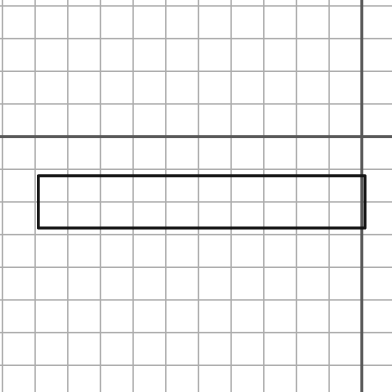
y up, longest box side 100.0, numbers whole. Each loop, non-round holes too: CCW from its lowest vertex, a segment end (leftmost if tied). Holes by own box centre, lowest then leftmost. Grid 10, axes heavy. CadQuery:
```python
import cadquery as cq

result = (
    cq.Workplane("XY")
    .moveTo(-99.0, -28.0)
    .lineTo(1.0, -28.0)
    .lineTo(1.0, -12.0)
    .lineTo(-99.0, -12.0)
    .close()
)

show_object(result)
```